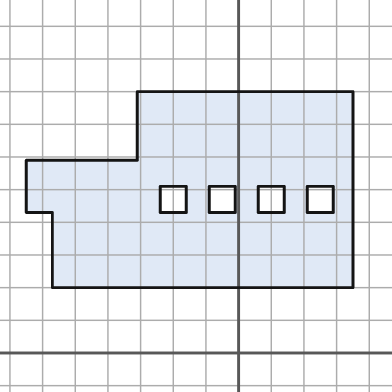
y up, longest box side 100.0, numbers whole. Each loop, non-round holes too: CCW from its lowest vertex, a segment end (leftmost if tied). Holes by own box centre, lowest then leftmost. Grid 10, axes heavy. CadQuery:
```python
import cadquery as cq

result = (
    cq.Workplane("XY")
    .moveTo(-57.0, 20.0)
    .lineTo(35.0, 20.0)
    .lineTo(35.0, 80.0)
    .lineTo(-31.0, 80.0)
    .lineTo(-31.0, 59.0)
    .lineTo(-65.0, 59.0)
    .lineTo(-65.0, 43.0)
    .lineTo(-57.0, 43.0)
    .close()
    .moveTo(-24.0, 43.0)
    .lineTo(-16.0, 43.0)
    .lineTo(-16.0, 51.0)
    .lineTo(-24.0, 51.0)
    .close()
    .moveTo(-9.0, 43.0)
    .lineTo(-1.0, 43.0)
    .lineTo(-1.0, 51.0)
    .lineTo(-9.0, 51.0)
    .close()
    .moveTo(6.0, 43.0)
    .lineTo(14.0, 43.0)
    .lineTo(14.0, 51.0)
    .lineTo(6.0, 51.0)
    .close()
    .moveTo(21.0, 43.0)
    .lineTo(29.0, 43.0)
    .lineTo(29.0, 51.0)
    .lineTo(21.0, 51.0)
    .close()
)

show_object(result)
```